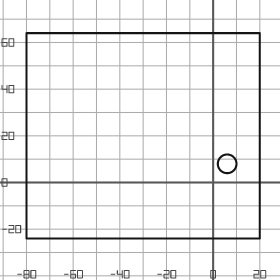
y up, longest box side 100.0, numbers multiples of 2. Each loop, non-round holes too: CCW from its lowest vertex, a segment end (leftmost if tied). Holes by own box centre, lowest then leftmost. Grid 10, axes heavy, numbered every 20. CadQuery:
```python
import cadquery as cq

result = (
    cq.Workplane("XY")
    .moveTo(-80.0, -24.0)
    .lineTo(20.0, -24.0)
    .lineTo(20.0, 64.0)
    .lineTo(-80.0, 64.0)
    .close()
    .moveTo(6.0, 8.0)
    .circle(4.0)
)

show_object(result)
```